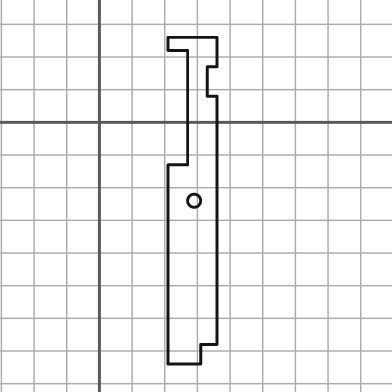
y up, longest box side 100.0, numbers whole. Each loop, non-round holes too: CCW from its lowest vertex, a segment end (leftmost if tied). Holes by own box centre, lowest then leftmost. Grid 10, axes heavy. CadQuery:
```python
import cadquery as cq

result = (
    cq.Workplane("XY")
    .moveTo(21.0, -74.0)
    .lineTo(31.0, -74.0)
    .lineTo(31.0, -68.0)
    .lineTo(36.0, -68.0)
    .lineTo(36.0, 8.0)
    .lineTo(33.0, 8.0)
    .lineTo(33.0, 17.0)
    .lineTo(36.0, 17.0)
    .lineTo(36.0, 26.0)
    .lineTo(21.0, 26.0)
    .lineTo(21.0, 22.0)
    .lineTo(27.0, 22.0)
    .lineTo(27.0, -13.0)
    .lineTo(21.0, -13.0)
    .close()
    .moveTo(29.0, -24.0)
    .circle(2.0)
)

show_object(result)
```